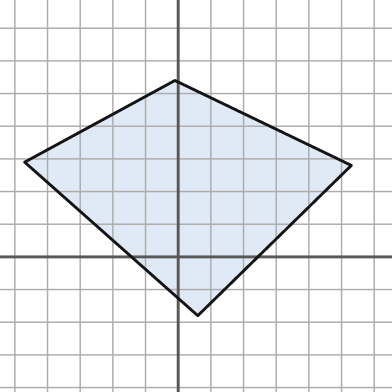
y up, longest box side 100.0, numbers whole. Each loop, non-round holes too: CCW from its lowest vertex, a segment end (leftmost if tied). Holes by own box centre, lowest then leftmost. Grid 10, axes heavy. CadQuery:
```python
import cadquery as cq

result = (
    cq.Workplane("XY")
    .moveTo(6.0, -18.0)
    .lineTo(53.0, 28.0)
    .lineTo(-1.0, 54.0)
    .lineTo(-47.0, 29.0)
    .close()
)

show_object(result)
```